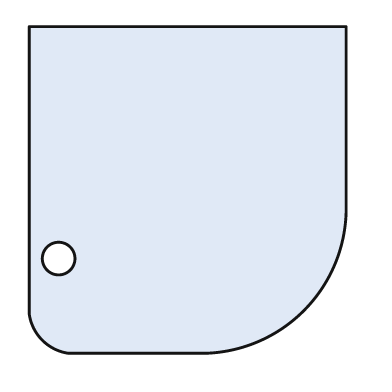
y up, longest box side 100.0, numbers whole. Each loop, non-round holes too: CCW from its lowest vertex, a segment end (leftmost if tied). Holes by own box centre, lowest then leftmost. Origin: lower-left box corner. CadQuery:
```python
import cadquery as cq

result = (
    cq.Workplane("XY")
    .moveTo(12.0, 0.0)
    .lineTo(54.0, 0.0)
    .threePointArc((84.0, 13.0), (97.0, 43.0))
    .lineTo(97.0, 100.0)
    .lineTo(0.0, 100.0)
    .lineTo(0.0, 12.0)
    .threePointArc((4.0, 4.0), (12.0, 0.0))
    .close()
    .moveTo(9.0, 29.0)
    .circle(5.0)
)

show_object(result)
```